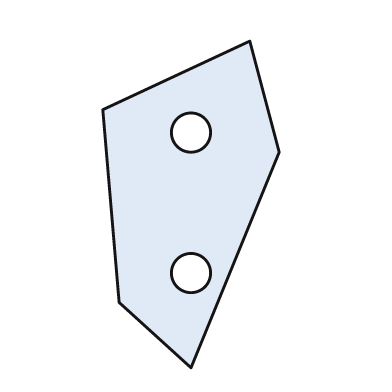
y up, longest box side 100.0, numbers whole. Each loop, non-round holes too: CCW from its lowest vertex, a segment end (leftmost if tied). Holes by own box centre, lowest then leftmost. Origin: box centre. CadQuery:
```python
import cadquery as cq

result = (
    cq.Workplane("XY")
    .moveTo(0.0, -50.0)
    .lineTo(27.0, 16.0)
    .lineTo(18.0, 50.0)
    .lineTo(-27.0, 29.0)
    .lineTo(-22.0, -30.0)
    .close()
    .moveTo(0.0, -21.0)
    .circle(6.0)
    .moveTo(0.0, 22.0)
    .circle(6.0)
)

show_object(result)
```